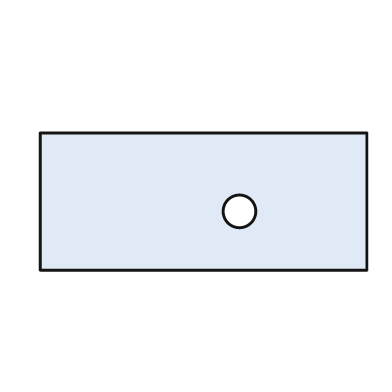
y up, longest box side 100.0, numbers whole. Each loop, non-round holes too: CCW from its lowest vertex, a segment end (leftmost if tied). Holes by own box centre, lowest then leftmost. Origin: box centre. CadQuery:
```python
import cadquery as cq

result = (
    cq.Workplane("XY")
    .moveTo(-50.0, -21.0)
    .lineTo(50.0, -21.0)
    .lineTo(50.0, 21.0)
    .lineTo(-50.0, 21.0)
    .close()
    .moveTo(11.0, -3.0)
    .circle(5.0)
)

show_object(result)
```